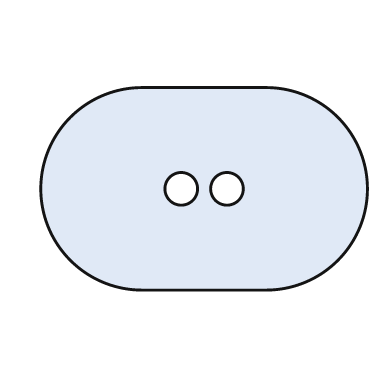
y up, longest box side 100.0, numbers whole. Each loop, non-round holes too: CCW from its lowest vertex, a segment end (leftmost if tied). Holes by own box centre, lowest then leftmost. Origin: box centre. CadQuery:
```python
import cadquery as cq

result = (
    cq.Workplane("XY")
    .moveTo(-19.0, -31.0)
    .lineTo(19.0, -31.0)
    .threePointArc((50.0, 0.0), (19.0, 31.0))
    .lineTo(-19.0, 31.0)
    .threePointArc((-50.0, 0.0), (-19.0, -31.0))
    .close()
    .moveTo(-7.0, 0.0)
    .circle(5.0)
    .moveTo(7.0, 0.0)
    .circle(5.0)
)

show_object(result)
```